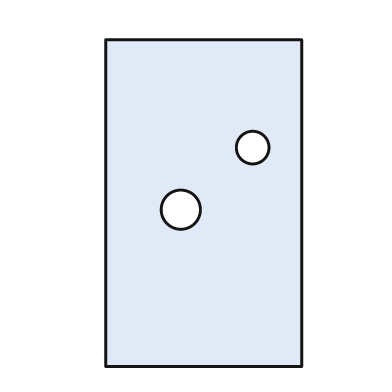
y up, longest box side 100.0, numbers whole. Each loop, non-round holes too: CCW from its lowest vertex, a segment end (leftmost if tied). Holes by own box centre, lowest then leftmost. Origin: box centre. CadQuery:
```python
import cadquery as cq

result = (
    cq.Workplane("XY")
    .moveTo(-30.0, -50.0)
    .lineTo(30.0, -50.0)
    .lineTo(30.0, 50.0)
    .lineTo(-30.0, 50.0)
    .close()
    .moveTo(-7.0, -2.0)
    .circle(6.0)
    .moveTo(15.0, 17.0)
    .circle(5.0)
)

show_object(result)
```